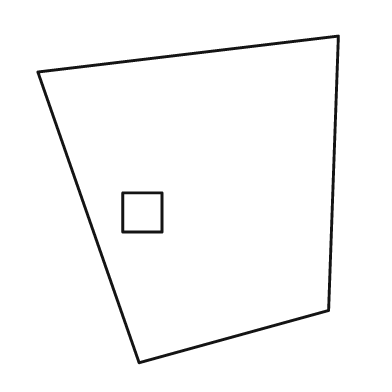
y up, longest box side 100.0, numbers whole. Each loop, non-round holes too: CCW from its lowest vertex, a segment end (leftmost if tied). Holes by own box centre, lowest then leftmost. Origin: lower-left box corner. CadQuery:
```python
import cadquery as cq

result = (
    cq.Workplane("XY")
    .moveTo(31.0, 0.0)
    .lineTo(89.0, 16.0)
    .lineTo(92.0, 100.0)
    .lineTo(0.0, 89.0)
    .close()
    .moveTo(26.0, 40.0)
    .lineTo(38.0, 40.0)
    .lineTo(38.0, 52.0)
    .lineTo(26.0, 52.0)
    .close()
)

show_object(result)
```